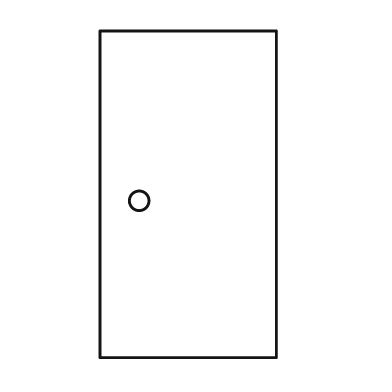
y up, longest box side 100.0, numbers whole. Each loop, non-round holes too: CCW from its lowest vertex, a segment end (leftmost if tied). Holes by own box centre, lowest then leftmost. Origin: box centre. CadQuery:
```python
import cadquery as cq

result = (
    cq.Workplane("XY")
    .moveTo(-27.0, -50.0)
    .lineTo(27.0, -50.0)
    .lineTo(27.0, 50.0)
    .lineTo(-27.0, 50.0)
    .close()
    .moveTo(-15.0, -2.0)
    .circle(3.0)
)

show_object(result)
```